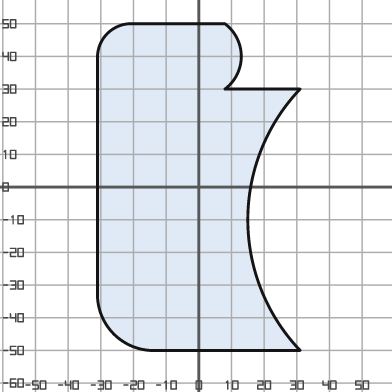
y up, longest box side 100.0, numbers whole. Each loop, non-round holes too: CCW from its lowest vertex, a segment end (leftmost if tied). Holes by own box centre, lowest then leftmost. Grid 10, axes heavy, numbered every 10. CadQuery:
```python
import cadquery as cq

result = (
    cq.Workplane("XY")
    .moveTo(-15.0, -50.0)
    .lineTo(31.0, -50.0)
    .threePointArc((15.0, -10.0), (31.0, 30.0))
    .lineTo(8.0, 30.0)
    .threePointArc((13.0, 40.0), (8.0, 50.0))
    .lineTo(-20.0, 50.0)
    .threePointArc((-28.0, 47.0), (-31.0, 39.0))
    .lineTo(-31.0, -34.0)
    .threePointArc((-26.0, -45.0), (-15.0, -50.0))
    .close()
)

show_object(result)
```